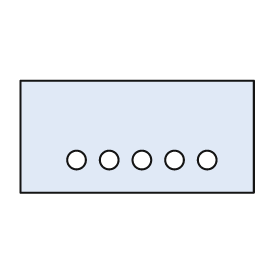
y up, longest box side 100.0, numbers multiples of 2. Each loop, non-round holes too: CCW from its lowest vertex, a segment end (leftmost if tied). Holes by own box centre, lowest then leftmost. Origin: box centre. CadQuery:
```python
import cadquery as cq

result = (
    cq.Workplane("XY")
    .moveTo(-50.0, -24.0)
    .lineTo(50.0, -24.0)
    .lineTo(50.0, 24.0)
    .lineTo(-50.0, 24.0)
    .close()
    .moveTo(-26.0, -10.0)
    .circle(4.0)
    .moveTo(-12.0, -10.0)
    .circle(4.0)
    .moveTo(2.0, -10.0)
    .circle(4.0)
    .moveTo(16.0, -10.0)
    .circle(4.0)
    .moveTo(30.0, -10.0)
    .circle(4.0)
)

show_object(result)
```